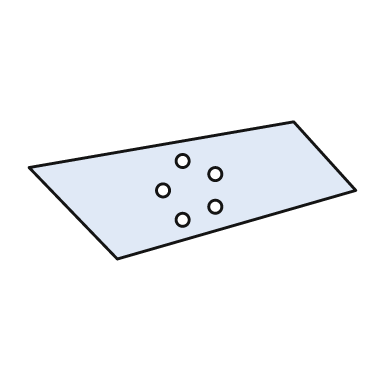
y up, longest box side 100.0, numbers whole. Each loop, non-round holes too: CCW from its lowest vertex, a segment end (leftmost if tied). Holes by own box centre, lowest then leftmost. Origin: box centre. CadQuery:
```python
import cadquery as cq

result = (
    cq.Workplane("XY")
    .moveTo(-23.0, -21.0)
    .lineTo(50.0, 0.0)
    .lineTo(31.0, 21.0)
    .lineTo(-50.0, 7.0)
    .close()
    .moveTo(-3.0, -9.0)
    .circle(2.0)
    .moveTo(7.0, -5.0)
    .circle(2.0)
    .moveTo(-9.0, 0.0)
    .circle(2.0)
    .moveTo(7.0, 5.0)
    .circle(2.0)
    .moveTo(-3.0, 9.0)
    .circle(2.0)
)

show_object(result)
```